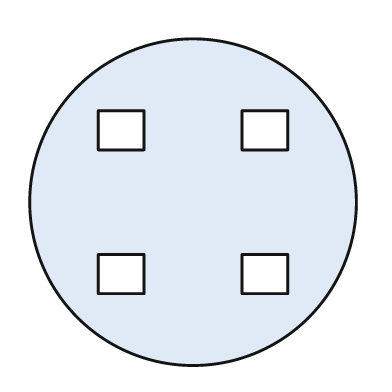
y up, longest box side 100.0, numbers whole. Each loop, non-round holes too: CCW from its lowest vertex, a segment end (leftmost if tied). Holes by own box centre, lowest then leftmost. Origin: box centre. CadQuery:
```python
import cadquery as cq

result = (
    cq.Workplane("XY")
    .moveTo(0.0, 0.0)
    .circle(50.0)
    .moveTo(-29.0, -28.0)
    .lineTo(-15.0, -28.0)
    .lineTo(-15.0, -16.0)
    .lineTo(-29.0, -16.0)
    .close()
    .moveTo(15.0, -28.0)
    .lineTo(29.0, -28.0)
    .lineTo(29.0, -16.0)
    .lineTo(15.0, -16.0)
    .close()
    .moveTo(-29.0, 16.0)
    .lineTo(-15.0, 16.0)
    .lineTo(-15.0, 28.0)
    .lineTo(-29.0, 28.0)
    .close()
    .moveTo(15.0, 16.0)
    .lineTo(29.0, 16.0)
    .lineTo(29.0, 28.0)
    .lineTo(15.0, 28.0)
    .close()
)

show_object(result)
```